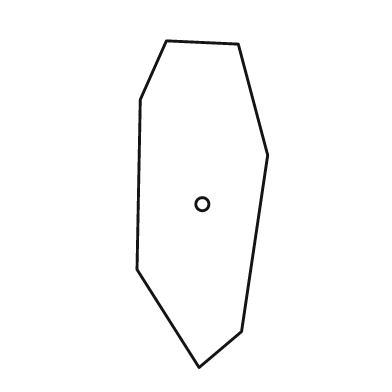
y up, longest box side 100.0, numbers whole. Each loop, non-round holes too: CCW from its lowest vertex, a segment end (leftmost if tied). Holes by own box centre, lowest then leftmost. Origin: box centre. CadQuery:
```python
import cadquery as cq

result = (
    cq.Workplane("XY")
    .moveTo(-1.0, -50.0)
    .lineTo(12.0, -39.0)
    .lineTo(20.0, 15.0)
    .lineTo(11.0, 49.0)
    .lineTo(-11.0, 50.0)
    .lineTo(-19.0, 32.0)
    .lineTo(-20.0, -20.0)
    .close()
    .moveTo(0.0, 0.0)
    .circle(2.0)
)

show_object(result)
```